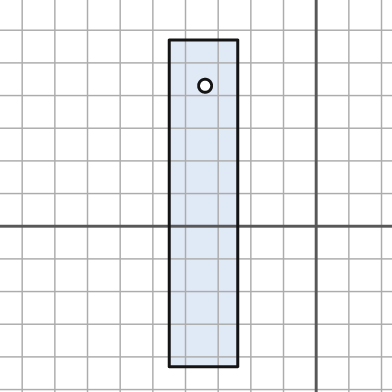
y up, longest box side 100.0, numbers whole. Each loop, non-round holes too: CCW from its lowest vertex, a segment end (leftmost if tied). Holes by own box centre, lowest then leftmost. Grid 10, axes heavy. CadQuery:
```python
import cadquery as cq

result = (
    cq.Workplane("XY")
    .moveTo(-45.0, -43.0)
    .lineTo(-24.0, -43.0)
    .lineTo(-24.0, 57.0)
    .lineTo(-45.0, 57.0)
    .close()
    .moveTo(-34.0, 43.0)
    .circle(2.0)
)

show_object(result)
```